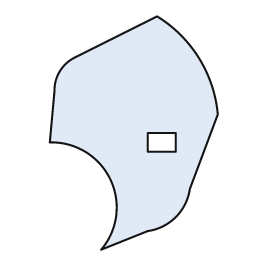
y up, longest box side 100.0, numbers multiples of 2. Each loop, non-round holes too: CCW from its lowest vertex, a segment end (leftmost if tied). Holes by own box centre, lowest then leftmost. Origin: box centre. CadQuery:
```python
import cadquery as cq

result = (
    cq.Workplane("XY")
    .moveTo(-14.0, -50.0)
    .lineTo(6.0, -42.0)
    .threePointArc((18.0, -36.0), (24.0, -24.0))
    .lineTo(36.0, 8.0)
    .threePointArc((28.0, 32.0), (10.0, 50.0))
    .lineTo(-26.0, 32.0)
    .threePointArc((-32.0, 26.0), (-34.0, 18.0))
    .lineTo(-36.0, -4.0)
    .threePointArc((-10.0, -20.0), (-14.0, -50.0))
    .close()
    .moveTo(6.0, -8.0)
    .lineTo(18.0, -8.0)
    .lineTo(18.0, 0.0)
    .lineTo(6.0, 0.0)
    .close()
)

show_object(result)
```